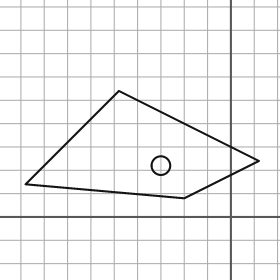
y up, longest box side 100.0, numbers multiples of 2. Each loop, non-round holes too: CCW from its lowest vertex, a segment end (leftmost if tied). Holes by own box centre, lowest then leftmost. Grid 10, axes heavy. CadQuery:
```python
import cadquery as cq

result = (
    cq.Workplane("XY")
    .moveTo(-20.0, 8.0)
    .lineTo(12.0, 24.0)
    .lineTo(-48.0, 54.0)
    .lineTo(-88.0, 14.0)
    .close()
    .moveTo(-30.0, 22.0)
    .circle(4.0)
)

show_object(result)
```